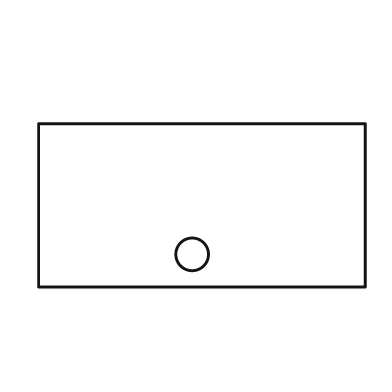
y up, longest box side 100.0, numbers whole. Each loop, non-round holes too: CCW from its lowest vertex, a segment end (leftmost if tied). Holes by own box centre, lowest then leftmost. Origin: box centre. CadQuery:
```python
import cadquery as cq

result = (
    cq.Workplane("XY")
    .moveTo(-50.0, -25.0)
    .lineTo(50.0, -25.0)
    .lineTo(50.0, 25.0)
    .lineTo(-50.0, 25.0)
    .close()
    .moveTo(-3.0, -15.0)
    .circle(5.0)
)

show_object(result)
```